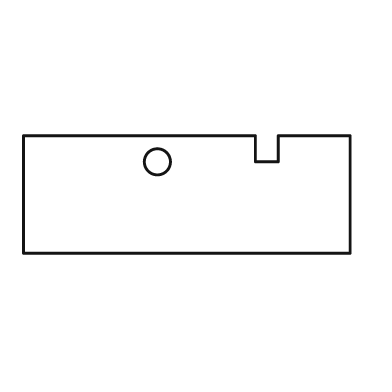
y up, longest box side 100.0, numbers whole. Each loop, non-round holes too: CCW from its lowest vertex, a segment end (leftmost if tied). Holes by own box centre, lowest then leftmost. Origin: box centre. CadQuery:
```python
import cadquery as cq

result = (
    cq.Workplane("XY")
    .moveTo(-50.0, -18.0)
    .lineTo(50.0, -18.0)
    .lineTo(50.0, 18.0)
    .lineTo(28.0, 18.0)
    .lineTo(28.0, 10.0)
    .lineTo(21.0, 10.0)
    .lineTo(21.0, 18.0)
    .lineTo(-50.0, 18.0)
    .close()
    .moveTo(-9.0, 10.0)
    .circle(4.0)
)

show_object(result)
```